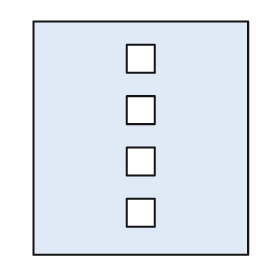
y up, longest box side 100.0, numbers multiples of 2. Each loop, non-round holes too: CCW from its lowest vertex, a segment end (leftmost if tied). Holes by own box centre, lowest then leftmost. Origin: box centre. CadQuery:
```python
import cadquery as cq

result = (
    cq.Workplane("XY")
    .moveTo(-46.0, -50.0)
    .lineTo(46.0, -50.0)
    .lineTo(46.0, 50.0)
    .lineTo(-46.0, 50.0)
    .close()
    .moveTo(-6.0, -38.0)
    .lineTo(6.0, -38.0)
    .lineTo(6.0, -26.0)
    .lineTo(-6.0, -26.0)
    .close()
    .moveTo(-6.0, -16.0)
    .lineTo(6.0, -16.0)
    .lineTo(6.0, -4.0)
    .lineTo(-6.0, -4.0)
    .close()
    .moveTo(-6.0, 6.0)
    .lineTo(6.0, 6.0)
    .lineTo(6.0, 18.0)
    .lineTo(-6.0, 18.0)
    .close()
    .moveTo(-6.0, 28.0)
    .lineTo(6.0, 28.0)
    .lineTo(6.0, 40.0)
    .lineTo(-6.0, 40.0)
    .close()
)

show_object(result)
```